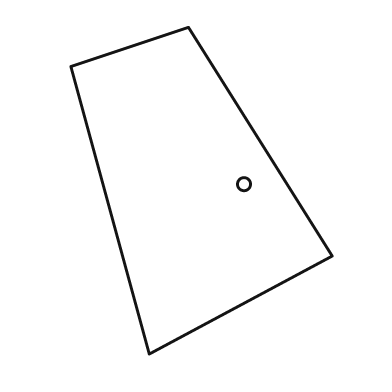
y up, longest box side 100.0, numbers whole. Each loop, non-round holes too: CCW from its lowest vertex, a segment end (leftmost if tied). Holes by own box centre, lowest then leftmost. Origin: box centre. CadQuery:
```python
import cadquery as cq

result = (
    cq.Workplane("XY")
    .moveTo(-16.0, -50.0)
    .lineTo(40.0, -20.0)
    .lineTo(-4.0, 50.0)
    .lineTo(-40.0, 38.0)
    .close()
    .moveTo(13.0, 2.0)
    .circle(2.0)
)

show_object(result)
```